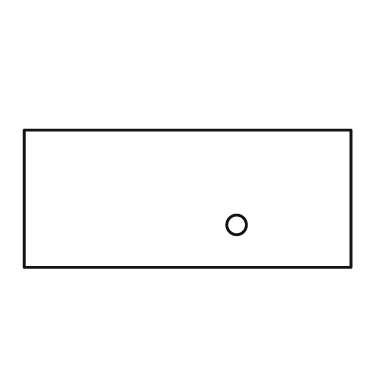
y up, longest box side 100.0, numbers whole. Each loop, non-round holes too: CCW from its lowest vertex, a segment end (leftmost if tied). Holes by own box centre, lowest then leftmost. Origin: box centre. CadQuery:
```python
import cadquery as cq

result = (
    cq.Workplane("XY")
    .moveTo(-50.0, -21.0)
    .lineTo(50.0, -21.0)
    .lineTo(50.0, 21.0)
    .lineTo(-50.0, 21.0)
    .close()
    .moveTo(15.0, -8.0)
    .circle(3.0)
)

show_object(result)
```